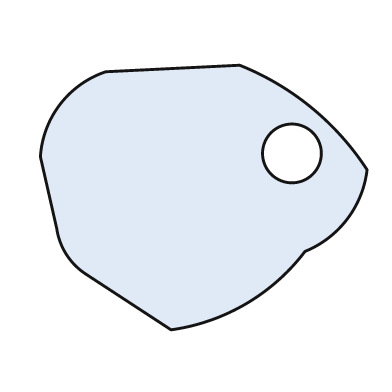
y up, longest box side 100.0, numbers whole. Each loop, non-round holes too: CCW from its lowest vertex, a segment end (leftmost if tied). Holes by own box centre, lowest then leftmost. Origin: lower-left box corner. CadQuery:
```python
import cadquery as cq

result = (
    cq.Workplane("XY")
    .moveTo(40.0, 0.0)
    .threePointArc((63.0, 8.0), (81.0, 24.0))
    .threePointArc((94.0, 34.0), (100.0, 49.0))
    .threePointArc((83.0, 68.0), (61.0, 81.0))
    .lineTo(20.0, 79.0)
    .threePointArc((6.0, 69.0), (0.0, 53.0))
    .lineTo(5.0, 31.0)
    .threePointArc((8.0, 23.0), (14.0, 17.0))
    .close()
    .moveTo(77.0, 54.0)
    .circle(9.0)
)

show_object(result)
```